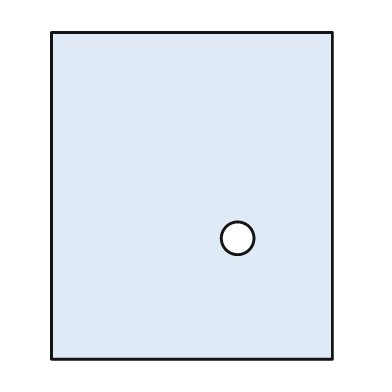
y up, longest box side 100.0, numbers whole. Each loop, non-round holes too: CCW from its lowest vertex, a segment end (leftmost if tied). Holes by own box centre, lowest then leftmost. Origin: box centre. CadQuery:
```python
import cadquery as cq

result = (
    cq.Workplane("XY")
    .moveTo(-43.0, -50.0)
    .lineTo(43.0, -50.0)
    .lineTo(43.0, 50.0)
    .lineTo(-43.0, 50.0)
    .close()
    .moveTo(14.0, -13.0)
    .circle(5.0)
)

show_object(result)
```